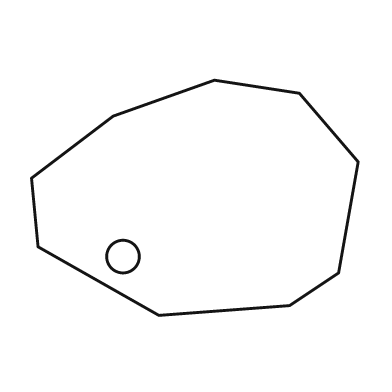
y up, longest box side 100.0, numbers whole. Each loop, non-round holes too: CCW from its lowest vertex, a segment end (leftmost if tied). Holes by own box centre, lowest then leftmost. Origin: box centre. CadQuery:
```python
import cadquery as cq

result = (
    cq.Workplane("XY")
    .moveTo(-11.0, -36.0)
    .lineTo(29.0, -33.0)
    .lineTo(44.0, -23.0)
    .lineTo(50.0, 11.0)
    .lineTo(32.0, 32.0)
    .lineTo(6.0, 36.0)
    .lineTo(-25.0, 25.0)
    .lineTo(-50.0, 6.0)
    .lineTo(-48.0, -15.0)
    .close()
    .moveTo(-22.0, -18.0)
    .circle(5.0)
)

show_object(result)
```